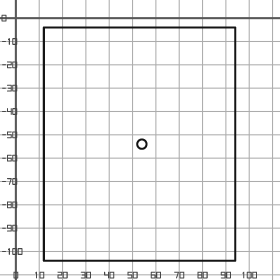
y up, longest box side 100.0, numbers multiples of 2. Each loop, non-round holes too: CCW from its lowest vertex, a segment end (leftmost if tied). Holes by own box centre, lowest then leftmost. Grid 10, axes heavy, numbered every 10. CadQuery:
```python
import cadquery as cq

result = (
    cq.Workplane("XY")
    .moveTo(12.0, -104.0)
    .lineTo(94.0, -104.0)
    .lineTo(94.0, -4.0)
    .lineTo(12.0, -4.0)
    .close()
    .moveTo(54.0, -54.0)
    .circle(2.0)
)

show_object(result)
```